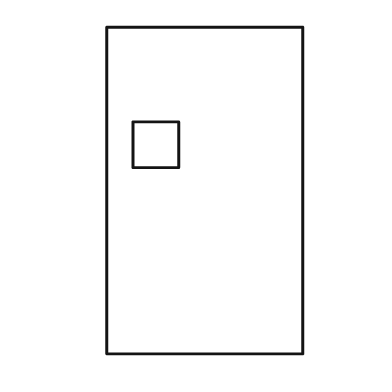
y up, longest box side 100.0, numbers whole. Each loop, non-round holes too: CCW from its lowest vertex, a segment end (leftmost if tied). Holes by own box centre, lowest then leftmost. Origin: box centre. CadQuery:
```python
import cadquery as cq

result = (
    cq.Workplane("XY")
    .moveTo(-30.0, -50.0)
    .lineTo(30.0, -50.0)
    .lineTo(30.0, 50.0)
    .lineTo(-30.0, 50.0)
    .close()
    .moveTo(-22.0, 7.0)
    .lineTo(-8.0, 7.0)
    .lineTo(-8.0, 21.0)
    .lineTo(-22.0, 21.0)
    .close()
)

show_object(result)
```